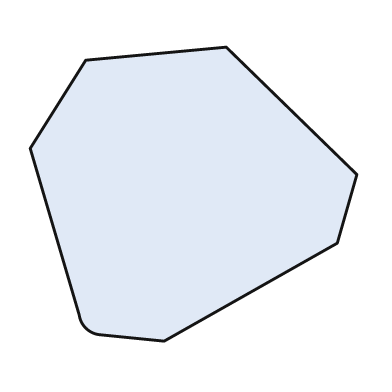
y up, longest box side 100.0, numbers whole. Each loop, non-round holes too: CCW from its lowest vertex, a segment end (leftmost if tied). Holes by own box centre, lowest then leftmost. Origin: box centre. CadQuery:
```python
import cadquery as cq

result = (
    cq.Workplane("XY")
    .moveTo(-9.0, -45.0)
    .lineTo(44.0, -15.0)
    .lineTo(50.0, 6.0)
    .lineTo(10.0, 45.0)
    .lineTo(-33.0, 41.0)
    .lineTo(-50.0, 14.0)
    .lineTo(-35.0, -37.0)
    .threePointArc((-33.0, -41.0), (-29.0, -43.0))
    .close()
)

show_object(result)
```